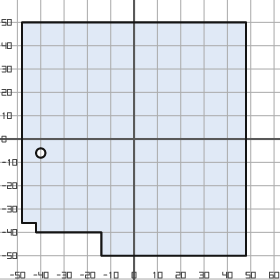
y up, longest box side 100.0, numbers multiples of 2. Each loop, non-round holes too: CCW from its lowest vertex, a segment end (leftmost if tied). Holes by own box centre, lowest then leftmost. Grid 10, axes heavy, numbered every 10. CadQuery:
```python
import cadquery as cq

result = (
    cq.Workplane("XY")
    .moveTo(-14.0, -50.0)
    .lineTo(48.0, -50.0)
    .lineTo(48.0, 50.0)
    .lineTo(-48.0, 50.0)
    .lineTo(-48.0, -36.0)
    .lineTo(-42.0, -36.0)
    .lineTo(-42.0, -40.0)
    .lineTo(-14.0, -40.0)
    .close()
    .moveTo(-40.0, -6.0)
    .circle(2.0)
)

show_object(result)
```